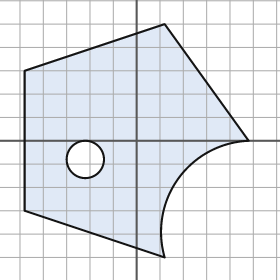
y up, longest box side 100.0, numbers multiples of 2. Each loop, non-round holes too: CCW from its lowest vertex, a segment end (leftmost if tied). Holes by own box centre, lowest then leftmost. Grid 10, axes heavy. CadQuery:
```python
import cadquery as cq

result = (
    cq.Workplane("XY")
    .moveTo(12.0, -50.0)
    .threePointArc((18.0, -16.0), (48.0, 0.0))
    .lineTo(12.0, 50.0)
    .lineTo(-48.0, 30.0)
    .lineTo(-48.0, -30.0)
    .close()
    .moveTo(-22.0, -8.0)
    .circle(8.0)
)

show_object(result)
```